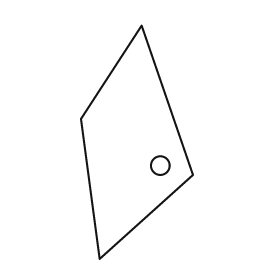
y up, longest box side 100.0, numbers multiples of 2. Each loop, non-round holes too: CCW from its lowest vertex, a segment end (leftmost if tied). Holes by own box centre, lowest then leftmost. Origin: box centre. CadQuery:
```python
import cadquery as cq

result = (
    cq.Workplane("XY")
    .moveTo(-16.0, -50.0)
    .lineTo(24.0, -14.0)
    .lineTo(2.0, 50.0)
    .lineTo(-24.0, 10.0)
    .close()
    .moveTo(10.0, -10.0)
    .circle(4.0)
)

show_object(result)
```